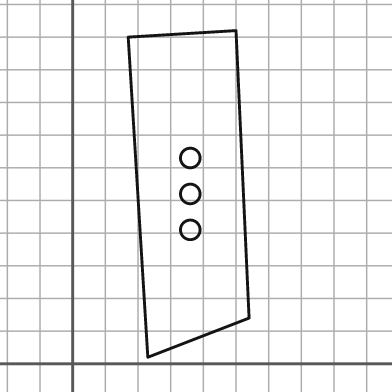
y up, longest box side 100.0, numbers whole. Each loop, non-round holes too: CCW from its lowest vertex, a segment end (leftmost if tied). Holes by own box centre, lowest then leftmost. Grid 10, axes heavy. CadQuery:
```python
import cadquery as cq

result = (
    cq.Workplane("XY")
    .moveTo(23.0, 2.0)
    .lineTo(54.0, 14.0)
    .lineTo(50.0, 102.0)
    .lineTo(17.0, 100.0)
    .close()
    .moveTo(36.0, 41.0)
    .circle(3.0)
    .moveTo(36.0, 52.0)
    .circle(3.0)
    .moveTo(36.0, 63.0)
    .circle(3.0)
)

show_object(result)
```